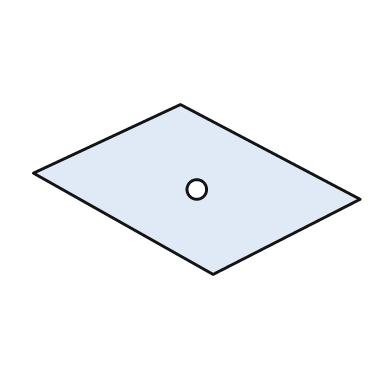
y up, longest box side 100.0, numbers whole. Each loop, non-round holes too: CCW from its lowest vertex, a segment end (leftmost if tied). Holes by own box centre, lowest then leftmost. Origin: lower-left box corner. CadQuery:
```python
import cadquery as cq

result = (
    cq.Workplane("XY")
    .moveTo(55.0, 0.0)
    .lineTo(100.0, 23.0)
    .lineTo(45.0, 52.0)
    .lineTo(0.0, 31.0)
    .close()
    .moveTo(50.0, 26.0)
    .circle(3.0)
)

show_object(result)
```